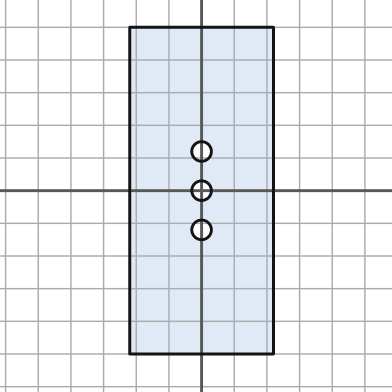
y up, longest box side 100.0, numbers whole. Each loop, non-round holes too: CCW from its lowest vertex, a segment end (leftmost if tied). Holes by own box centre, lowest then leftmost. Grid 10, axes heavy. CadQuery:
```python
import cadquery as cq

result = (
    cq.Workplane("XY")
    .moveTo(-22.0, -50.0)
    .lineTo(22.0, -50.0)
    .lineTo(22.0, 50.0)
    .lineTo(-22.0, 50.0)
    .close()
    .moveTo(0.0, -12.0)
    .circle(3.0)
    .moveTo(0.0, 0.0)
    .circle(3.0)
    .moveTo(0.0, 12.0)
    .circle(3.0)
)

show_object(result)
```